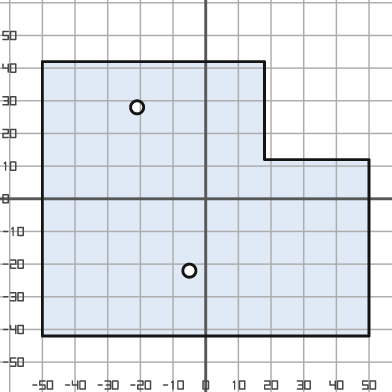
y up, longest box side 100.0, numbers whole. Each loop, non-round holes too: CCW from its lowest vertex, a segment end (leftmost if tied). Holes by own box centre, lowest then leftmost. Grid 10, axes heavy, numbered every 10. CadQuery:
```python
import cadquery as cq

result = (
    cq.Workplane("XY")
    .moveTo(-50.0, -42.0)
    .lineTo(50.0, -42.0)
    .lineTo(50.0, 12.0)
    .lineTo(18.0, 12.0)
    .lineTo(18.0, 42.0)
    .lineTo(-50.0, 42.0)
    .close()
    .moveTo(-5.0, -22.0)
    .circle(2.0)
    .moveTo(-21.0, 28.0)
    .circle(2.0)
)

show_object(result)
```